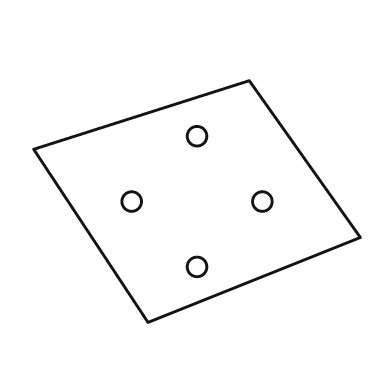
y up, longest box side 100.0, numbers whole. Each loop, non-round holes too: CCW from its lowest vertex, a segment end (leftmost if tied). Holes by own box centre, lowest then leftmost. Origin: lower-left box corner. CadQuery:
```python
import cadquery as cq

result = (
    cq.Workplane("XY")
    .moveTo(35.0, 0.0)
    .lineTo(100.0, 26.0)
    .lineTo(66.0, 74.0)
    .lineTo(0.0, 53.0)
    .close()
    .moveTo(50.0, 17.0)
    .circle(3.0)
    .moveTo(30.0, 37.0)
    .circle(3.0)
    .moveTo(70.0, 37.0)
    .circle(3.0)
    .moveTo(50.0, 57.0)
    .circle(3.0)
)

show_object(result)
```